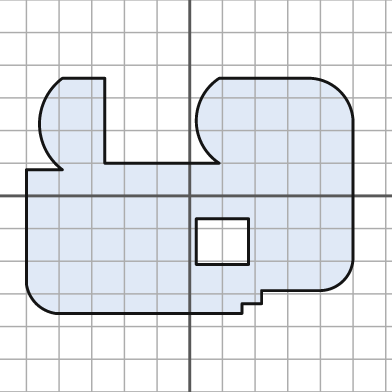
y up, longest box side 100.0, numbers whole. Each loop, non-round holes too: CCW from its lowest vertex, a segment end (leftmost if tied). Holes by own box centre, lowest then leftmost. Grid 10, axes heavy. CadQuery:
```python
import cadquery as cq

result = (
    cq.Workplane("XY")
    .moveTo(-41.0, -36.0)
    .lineTo(16.0, -36.0)
    .lineTo(16.0, -33.0)
    .lineTo(22.0, -33.0)
    .lineTo(22.0, -29.0)
    .lineTo(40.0, -29.0)
    .threePointArc((47.0, -26.0), (50.0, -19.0))
    .lineTo(50.0, 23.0)
    .threePointArc((46.0, 32.0), (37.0, 36.0))
    .lineTo(9.0, 36.0)
    .threePointArc((2.0, 23.0), (9.0, 10.0))
    .lineTo(-26.0, 10.0)
    .lineTo(-26.0, 36.0)
    .lineTo(-39.0, 36.0)
    .threePointArc((-46.0, 22.0), (-39.0, 8.0))
    .lineTo(-50.0, 8.0)
    .lineTo(-50.0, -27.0)
    .threePointArc((-47.0, -33.0), (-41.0, -36.0))
    .close()
    .moveTo(2.0, -21.0)
    .lineTo(18.0, -21.0)
    .lineTo(18.0, -7.0)
    .lineTo(2.0, -7.0)
    .close()
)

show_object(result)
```